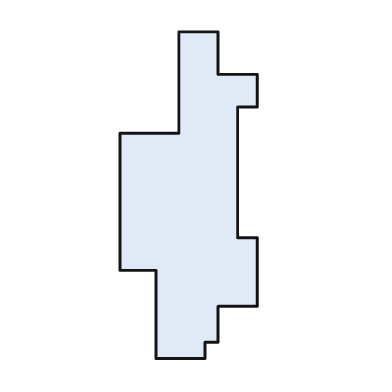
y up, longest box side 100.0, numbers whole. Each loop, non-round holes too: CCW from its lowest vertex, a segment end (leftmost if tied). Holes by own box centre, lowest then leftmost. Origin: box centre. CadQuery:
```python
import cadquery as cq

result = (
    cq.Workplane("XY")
    .moveTo(-10.0, -50.0)
    .lineTo(5.0, -50.0)
    .lineTo(5.0, -45.0)
    .lineTo(9.0, -45.0)
    .lineTo(9.0, -34.0)
    .lineTo(21.0, -34.0)
    .lineTo(21.0, -13.0)
    .lineTo(15.0, -13.0)
    .lineTo(15.0, 27.0)
    .lineTo(21.0, 27.0)
    .lineTo(21.0, 37.0)
    .lineTo(9.0, 37.0)
    .lineTo(9.0, 50.0)
    .lineTo(-3.0, 50.0)
    .lineTo(-3.0, 19.0)
    .lineTo(-21.0, 19.0)
    .lineTo(-21.0, -23.0)
    .lineTo(-10.0, -23.0)
    .close()
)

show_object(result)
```